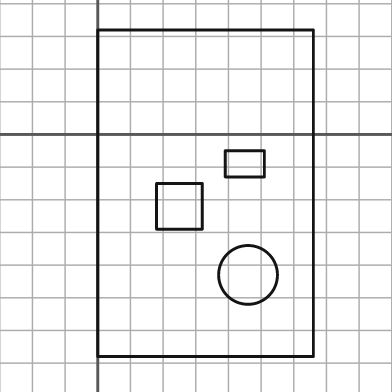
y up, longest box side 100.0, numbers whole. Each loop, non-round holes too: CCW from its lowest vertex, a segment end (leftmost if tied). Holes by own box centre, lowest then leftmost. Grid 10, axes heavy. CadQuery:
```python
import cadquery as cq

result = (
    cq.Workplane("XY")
    .moveTo(0.0, -68.0)
    .lineTo(66.0, -68.0)
    .lineTo(66.0, 32.0)
    .lineTo(0.0, 32.0)
    .close()
    .moveTo(46.0, -43.0)
    .circle(9.0)
    .moveTo(18.0, -29.0)
    .lineTo(32.0, -29.0)
    .lineTo(32.0, -15.0)
    .lineTo(18.0, -15.0)
    .close()
    .moveTo(39.0, -13.0)
    .lineTo(51.0, -13.0)
    .lineTo(51.0, -5.0)
    .lineTo(39.0, -5.0)
    .close()
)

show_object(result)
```